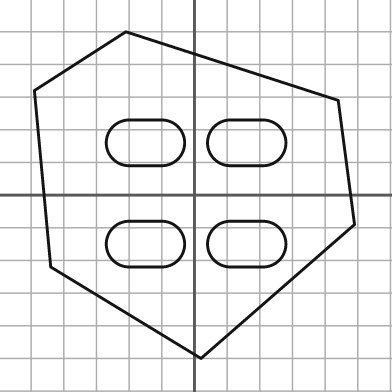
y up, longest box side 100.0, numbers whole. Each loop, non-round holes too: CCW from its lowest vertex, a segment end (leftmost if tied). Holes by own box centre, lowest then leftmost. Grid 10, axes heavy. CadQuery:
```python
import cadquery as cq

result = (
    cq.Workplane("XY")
    .moveTo(2.0, -50.0)
    .lineTo(49.0, -9.0)
    .lineTo(44.0, 29.0)
    .lineTo(-21.0, 50.0)
    .lineTo(-49.0, 32.0)
    .lineTo(-44.0, -22.0)
    .close()
    .moveTo(-20.0, -22.0)
    .lineTo(-10.0, -22.0)
    .threePointArc((-3.0, -15.0), (-10.0, -8.0))
    .lineTo(-20.0, -8.0)
    .threePointArc((-27.0, -15.0), (-20.0, -22.0))
    .close()
    .moveTo(11.0, -22.0)
    .lineTo(21.0, -22.0)
    .threePointArc((28.0, -15.0), (21.0, -8.0))
    .lineTo(11.0, -8.0)
    .threePointArc((4.0, -15.0), (11.0, -22.0))
    .close()
    .moveTo(-20.0, 9.0)
    .lineTo(-10.0, 9.0)
    .threePointArc((-3.0, 16.0), (-10.0, 23.0))
    .lineTo(-20.0, 23.0)
    .threePointArc((-27.0, 16.0), (-20.0, 9.0))
    .close()
    .moveTo(11.0, 9.0)
    .lineTo(21.0, 9.0)
    .threePointArc((28.0, 16.0), (21.0, 23.0))
    .lineTo(11.0, 23.0)
    .threePointArc((4.0, 16.0), (11.0, 9.0))
    .close()
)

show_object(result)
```